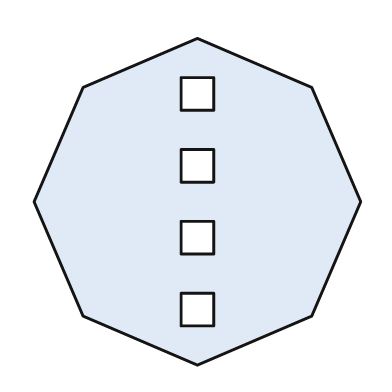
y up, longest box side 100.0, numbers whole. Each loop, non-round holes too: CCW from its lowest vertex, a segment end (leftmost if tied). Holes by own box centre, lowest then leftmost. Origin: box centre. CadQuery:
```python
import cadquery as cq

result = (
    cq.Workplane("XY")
    .moveTo(0.0, -50.0)
    .lineTo(35.0, -35.0)
    .lineTo(50.0, 0.0)
    .lineTo(35.0, 35.0)
    .lineTo(0.0, 50.0)
    .lineTo(-35.0, 35.0)
    .lineTo(-50.0, 0.0)
    .lineTo(-35.0, -35.0)
    .close()
    .moveTo(-5.0, -38.0)
    .lineTo(5.0, -38.0)
    .lineTo(5.0, -28.0)
    .lineTo(-5.0, -28.0)
    .close()
    .moveTo(-5.0, -16.0)
    .lineTo(5.0, -16.0)
    .lineTo(5.0, -6.0)
    .lineTo(-5.0, -6.0)
    .close()
    .moveTo(-5.0, 6.0)
    .lineTo(5.0, 6.0)
    .lineTo(5.0, 16.0)
    .lineTo(-5.0, 16.0)
    .close()
    .moveTo(-5.0, 28.0)
    .lineTo(5.0, 28.0)
    .lineTo(5.0, 38.0)
    .lineTo(-5.0, 38.0)
    .close()
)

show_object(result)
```